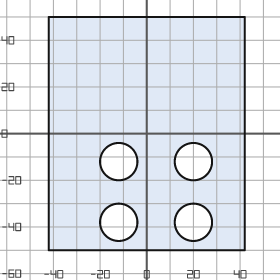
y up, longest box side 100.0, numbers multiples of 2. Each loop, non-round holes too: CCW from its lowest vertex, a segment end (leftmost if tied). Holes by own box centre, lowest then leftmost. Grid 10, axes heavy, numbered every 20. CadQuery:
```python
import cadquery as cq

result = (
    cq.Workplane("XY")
    .moveTo(-42.0, -50.0)
    .lineTo(42.0, -50.0)
    .lineTo(42.0, 50.0)
    .lineTo(-42.0, 50.0)
    .close()
    .moveTo(-12.0, -38.0)
    .circle(8.0)
    .moveTo(20.0, -38.0)
    .circle(8.0)
    .moveTo(-12.0, -12.0)
    .circle(8.0)
    .moveTo(20.0, -12.0)
    .circle(8.0)
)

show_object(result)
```